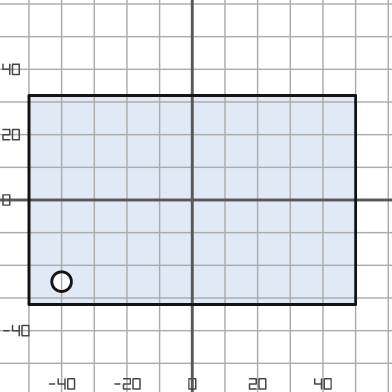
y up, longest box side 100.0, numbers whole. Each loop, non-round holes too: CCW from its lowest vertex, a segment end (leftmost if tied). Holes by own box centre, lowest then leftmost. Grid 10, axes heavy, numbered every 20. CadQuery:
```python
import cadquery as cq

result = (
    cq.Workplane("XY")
    .moveTo(-50.0, -32.0)
    .lineTo(50.0, -32.0)
    .lineTo(50.0, 32.0)
    .lineTo(-50.0, 32.0)
    .close()
    .moveTo(-40.0, -25.0)
    .circle(3.0)
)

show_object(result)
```